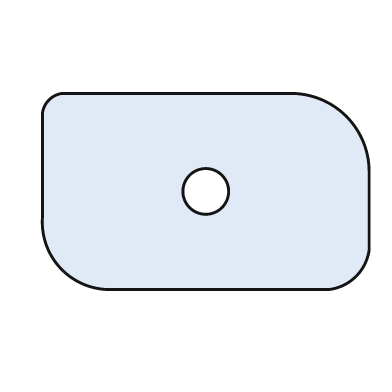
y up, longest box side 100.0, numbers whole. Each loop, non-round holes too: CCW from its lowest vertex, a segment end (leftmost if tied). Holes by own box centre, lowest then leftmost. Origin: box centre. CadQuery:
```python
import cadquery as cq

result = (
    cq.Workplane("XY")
    .moveTo(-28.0, -30.0)
    .lineTo(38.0, -30.0)
    .threePointArc((46.0, -26.0), (50.0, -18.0))
    .lineTo(50.0, 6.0)
    .threePointArc((43.0, 23.0), (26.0, 30.0))
    .lineTo(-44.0, 30.0)
    .threePointArc((-48.0, 28.0), (-50.0, 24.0))
    .lineTo(-50.0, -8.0)
    .threePointArc((-44.0, -24.0), (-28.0, -30.0))
    .close()
    .moveTo(0.0, 0.0)
    .circle(7.0)
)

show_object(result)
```